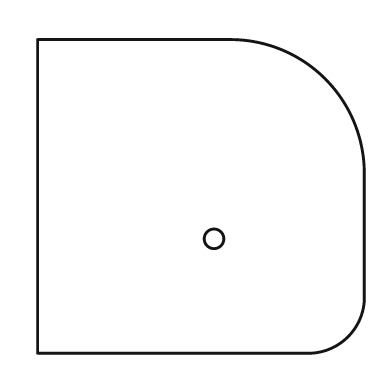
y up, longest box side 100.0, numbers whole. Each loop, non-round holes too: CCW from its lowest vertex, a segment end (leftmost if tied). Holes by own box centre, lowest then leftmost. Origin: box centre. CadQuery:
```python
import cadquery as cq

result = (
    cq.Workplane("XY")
    .moveTo(-50.0, -48.0)
    .lineTo(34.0, -48.0)
    .threePointArc((45.0, -43.0), (50.0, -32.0))
    .lineTo(50.0, 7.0)
    .threePointArc((38.0, 36.0), (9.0, 48.0))
    .lineTo(-50.0, 48.0)
    .close()
    .moveTo(4.0, -13.0)
    .circle(3.0)
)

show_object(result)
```